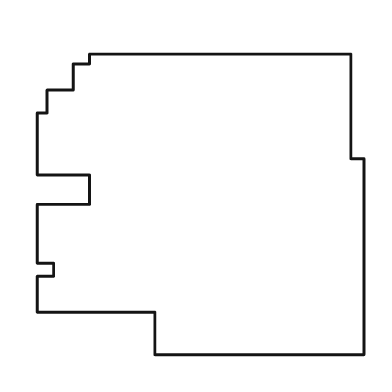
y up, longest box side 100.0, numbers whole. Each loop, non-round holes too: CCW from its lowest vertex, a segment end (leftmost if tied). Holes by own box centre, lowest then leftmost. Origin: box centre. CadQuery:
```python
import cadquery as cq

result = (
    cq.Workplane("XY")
    .moveTo(-14.0, -46.0)
    .lineTo(50.0, -46.0)
    .lineTo(50.0, 14.0)
    .lineTo(46.0, 14.0)
    .lineTo(46.0, 46.0)
    .lineTo(-34.0, 46.0)
    .lineTo(-34.0, 43.0)
    .lineTo(-39.0, 43.0)
    .lineTo(-39.0, 35.0)
    .lineTo(-47.0, 35.0)
    .lineTo(-47.0, 28.0)
    .lineTo(-50.0, 28.0)
    .lineTo(-50.0, 9.0)
    .lineTo(-34.0, 9.0)
    .lineTo(-34.0, 0.0)
    .lineTo(-50.0, 0.0)
    .lineTo(-50.0, -18.0)
    .lineTo(-45.0, -18.0)
    .lineTo(-45.0, -22.0)
    .lineTo(-50.0, -22.0)
    .lineTo(-50.0, -33.0)
    .lineTo(-14.0, -33.0)
    .close()
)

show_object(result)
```